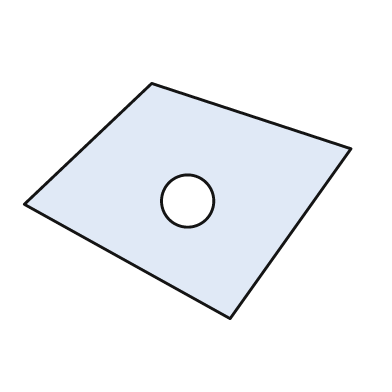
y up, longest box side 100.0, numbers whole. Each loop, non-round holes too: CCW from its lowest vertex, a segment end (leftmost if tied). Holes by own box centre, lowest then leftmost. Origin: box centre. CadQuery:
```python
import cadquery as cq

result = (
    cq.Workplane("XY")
    .moveTo(13.0, -36.0)
    .lineTo(50.0, 16.0)
    .lineTo(-11.0, 36.0)
    .lineTo(-50.0, -1.0)
    .close()
    .moveTo(0.0, 0.0)
    .circle(8.0)
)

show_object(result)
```